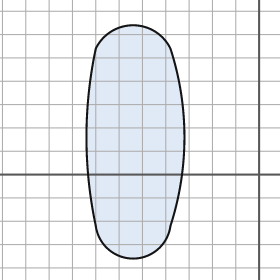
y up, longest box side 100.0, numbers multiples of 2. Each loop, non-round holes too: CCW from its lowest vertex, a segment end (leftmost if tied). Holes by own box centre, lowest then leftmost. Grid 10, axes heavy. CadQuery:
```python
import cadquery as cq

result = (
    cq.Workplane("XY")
    .moveTo(-70.0, -22.0)
    .threePointArc((-54.0, -36.0), (-38.0, -22.0))
    .threePointArc((-32.0, 16.0), (-38.0, 54.0))
    .threePointArc((-54.0, 64.0), (-70.0, 54.0))
    .threePointArc((-74.0, 16.0), (-70.0, -22.0))
    .close()
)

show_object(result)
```